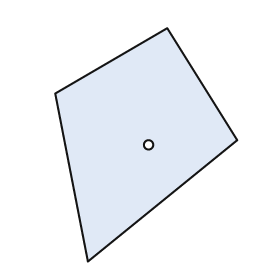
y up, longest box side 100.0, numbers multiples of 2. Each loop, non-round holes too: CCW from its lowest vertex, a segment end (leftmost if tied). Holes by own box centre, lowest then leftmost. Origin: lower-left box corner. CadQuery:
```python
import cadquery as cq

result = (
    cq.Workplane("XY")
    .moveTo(14.0, 0.0)
    .lineTo(78.0, 52.0)
    .lineTo(48.0, 100.0)
    .lineTo(0.0, 72.0)
    .close()
    .moveTo(40.0, 50.0)
    .circle(2.0)
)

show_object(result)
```